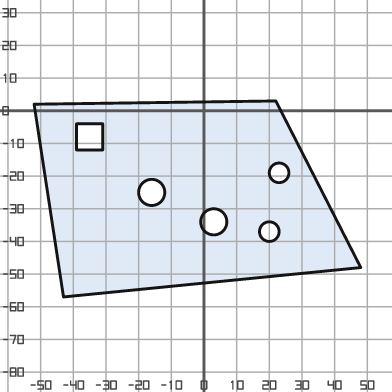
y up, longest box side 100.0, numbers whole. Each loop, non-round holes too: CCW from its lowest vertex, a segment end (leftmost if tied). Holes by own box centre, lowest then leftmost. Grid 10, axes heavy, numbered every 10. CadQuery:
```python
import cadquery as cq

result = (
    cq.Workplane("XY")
    .moveTo(-43.0, -57.0)
    .lineTo(48.0, -48.0)
    .lineTo(22.0, 3.0)
    .lineTo(-52.0, 2.0)
    .close()
    .moveTo(20.0, -37.0)
    .circle(3.0)
    .moveTo(3.0, -34.0)
    .circle(4.0)
    .moveTo(-16.0, -25.0)
    .circle(4.0)
    .moveTo(23.0, -19.0)
    .circle(3.0)
    .moveTo(-39.0, -12.0)
    .lineTo(-31.0, -12.0)
    .lineTo(-31.0, -4.0)
    .lineTo(-39.0, -4.0)
    .close()
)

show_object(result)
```